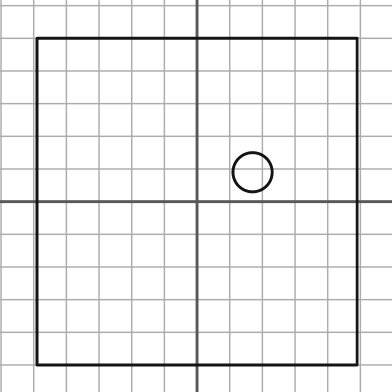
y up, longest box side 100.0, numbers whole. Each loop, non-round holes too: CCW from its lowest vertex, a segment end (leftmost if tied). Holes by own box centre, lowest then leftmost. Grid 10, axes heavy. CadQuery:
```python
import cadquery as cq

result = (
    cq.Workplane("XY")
    .moveTo(-49.0, -50.0)
    .lineTo(49.0, -50.0)
    .lineTo(49.0, 50.0)
    .lineTo(-49.0, 50.0)
    .close()
    .moveTo(17.0, 9.0)
    .circle(6.0)
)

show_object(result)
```